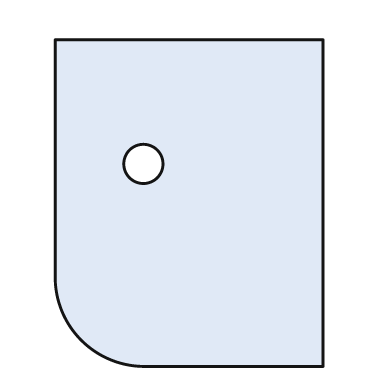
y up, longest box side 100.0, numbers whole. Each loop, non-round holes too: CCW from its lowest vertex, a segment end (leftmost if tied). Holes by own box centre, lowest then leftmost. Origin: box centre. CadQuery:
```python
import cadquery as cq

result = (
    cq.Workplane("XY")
    .moveTo(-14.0, -50.0)
    .lineTo(41.0, -50.0)
    .lineTo(41.0, 50.0)
    .lineTo(-41.0, 50.0)
    .lineTo(-41.0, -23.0)
    .threePointArc((-33.0, -42.0), (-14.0, -50.0))
    .close()
    .moveTo(-14.0, 12.0)
    .circle(6.0)
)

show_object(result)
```